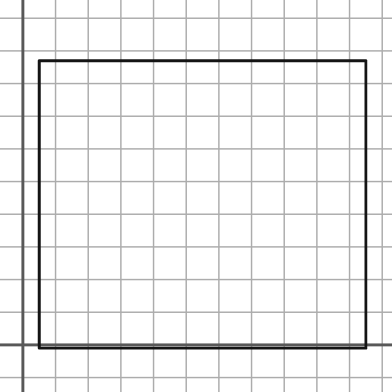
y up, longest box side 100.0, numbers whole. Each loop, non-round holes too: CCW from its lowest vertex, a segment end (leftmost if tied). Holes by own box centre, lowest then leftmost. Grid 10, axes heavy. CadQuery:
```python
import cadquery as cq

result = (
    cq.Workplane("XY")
    .moveTo(5.0, -1.0)
    .lineTo(105.0, -1.0)
    .lineTo(105.0, 87.0)
    .lineTo(5.0, 87.0)
    .close()
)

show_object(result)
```